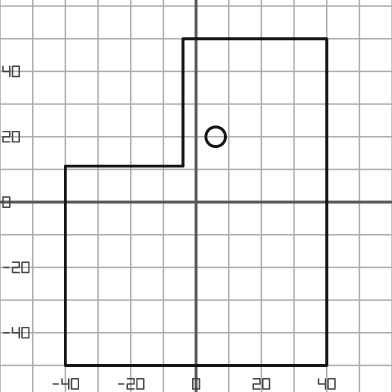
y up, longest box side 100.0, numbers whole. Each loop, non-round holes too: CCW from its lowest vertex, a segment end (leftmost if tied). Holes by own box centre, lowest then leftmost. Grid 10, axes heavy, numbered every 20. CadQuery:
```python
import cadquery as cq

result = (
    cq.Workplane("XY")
    .moveTo(-40.0, -50.0)
    .lineTo(40.0, -50.0)
    .lineTo(40.0, 50.0)
    .lineTo(-4.0, 50.0)
    .lineTo(-4.0, 11.0)
    .lineTo(-40.0, 11.0)
    .close()
    .moveTo(6.0, 20.0)
    .circle(3.0)
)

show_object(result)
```